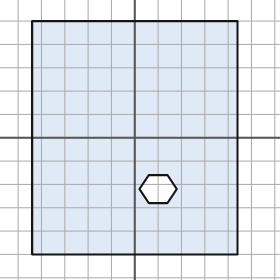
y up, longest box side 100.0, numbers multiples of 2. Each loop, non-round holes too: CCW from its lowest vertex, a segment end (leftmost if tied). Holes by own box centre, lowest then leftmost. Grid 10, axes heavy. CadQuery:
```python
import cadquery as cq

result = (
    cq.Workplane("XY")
    .moveTo(-44.0, -50.0)
    .lineTo(44.0, -50.0)
    .lineTo(44.0, 50.0)
    .lineTo(-44.0, 50.0)
    .close()
    .moveTo(6.0, -28.0)
    .lineTo(14.0, -28.0)
    .lineTo(18.0, -22.0)
    .lineTo(14.0, -16.0)
    .lineTo(6.0, -16.0)
    .lineTo(2.0, -22.0)
    .close()
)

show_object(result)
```